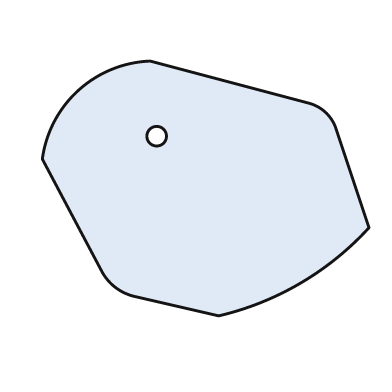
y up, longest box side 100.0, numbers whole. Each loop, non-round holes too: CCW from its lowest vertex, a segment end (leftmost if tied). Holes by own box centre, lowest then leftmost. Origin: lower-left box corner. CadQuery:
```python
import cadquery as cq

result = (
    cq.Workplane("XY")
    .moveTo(54.0, 0.0)
    .threePointArc((79.0, 10.0), (100.0, 27.0))
    .lineTo(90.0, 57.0)
    .threePointArc((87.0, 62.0), (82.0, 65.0))
    .lineTo(33.0, 78.0)
    .threePointArc((11.0, 69.0), (0.0, 48.0))
    .lineTo(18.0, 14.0)
    .threePointArc((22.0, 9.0), (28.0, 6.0))
    .close()
    .moveTo(35.0, 55.0)
    .circle(3.0)
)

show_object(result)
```